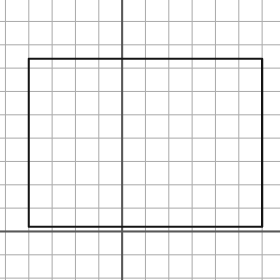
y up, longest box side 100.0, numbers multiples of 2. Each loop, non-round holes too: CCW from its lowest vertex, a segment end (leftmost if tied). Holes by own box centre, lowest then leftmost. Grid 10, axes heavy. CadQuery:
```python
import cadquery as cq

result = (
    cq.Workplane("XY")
    .moveTo(-40.0, 2.0)
    .lineTo(60.0, 2.0)
    .lineTo(60.0, 74.0)
    .lineTo(-40.0, 74.0)
    .close()
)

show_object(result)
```